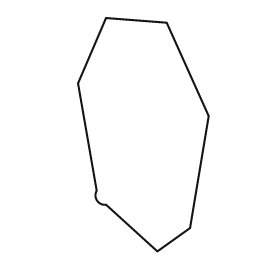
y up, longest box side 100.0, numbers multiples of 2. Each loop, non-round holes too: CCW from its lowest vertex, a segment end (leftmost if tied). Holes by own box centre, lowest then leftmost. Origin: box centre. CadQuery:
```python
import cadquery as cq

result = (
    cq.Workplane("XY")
    .moveTo(6.0, -50.0)
    .lineTo(20.0, -40.0)
    .lineTo(28.0, 8.0)
    .lineTo(10.0, 48.0)
    .lineTo(-16.0, 50.0)
    .lineTo(-28.0, 22.0)
    .lineTo(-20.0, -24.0)
    .threePointArc((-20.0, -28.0), (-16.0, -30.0))
    .close()
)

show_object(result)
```